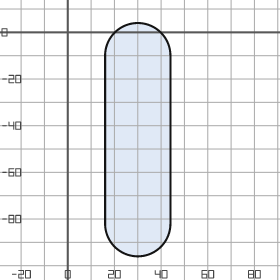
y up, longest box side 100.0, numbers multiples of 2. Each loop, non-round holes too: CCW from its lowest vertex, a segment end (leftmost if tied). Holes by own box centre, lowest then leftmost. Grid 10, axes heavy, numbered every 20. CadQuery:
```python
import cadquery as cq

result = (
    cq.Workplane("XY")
    .moveTo(16.0, -82.0)
    .threePointArc((30.0, -96.0), (44.0, -82.0))
    .lineTo(44.0, -10.0)
    .threePointArc((30.0, 4.0), (16.0, -10.0))
    .close()
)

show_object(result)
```